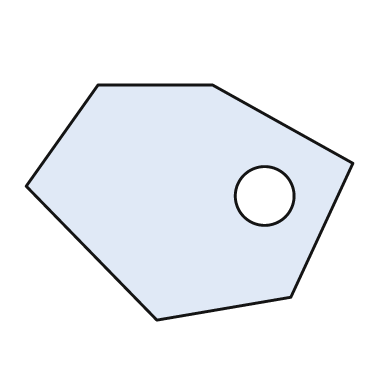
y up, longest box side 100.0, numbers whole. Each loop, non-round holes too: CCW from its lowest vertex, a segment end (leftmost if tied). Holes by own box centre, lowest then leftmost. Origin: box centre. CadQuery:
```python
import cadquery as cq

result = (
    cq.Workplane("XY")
    .moveTo(-10.0, -36.0)
    .lineTo(31.0, -29.0)
    .lineTo(50.0, 12.0)
    .lineTo(7.0, 36.0)
    .lineTo(-28.0, 36.0)
    .lineTo(-50.0, 5.0)
    .close()
    .moveTo(23.0, 2.0)
    .circle(9.0)
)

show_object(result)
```